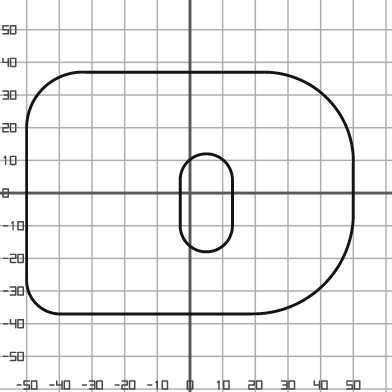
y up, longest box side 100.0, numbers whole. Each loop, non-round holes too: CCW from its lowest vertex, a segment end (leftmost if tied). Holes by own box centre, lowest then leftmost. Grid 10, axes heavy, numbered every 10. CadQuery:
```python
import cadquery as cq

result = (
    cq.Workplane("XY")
    .moveTo(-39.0, -37.0)
    .lineTo(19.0, -37.0)
    .threePointArc((41.0, -28.0), (50.0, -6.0))
    .lineTo(50.0, 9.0)
    .threePointArc((42.0, 29.0), (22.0, 37.0))
    .lineTo(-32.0, 37.0)
    .threePointArc((-45.0, 32.0), (-50.0, 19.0))
    .lineTo(-50.0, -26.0)
    .threePointArc((-47.0, -34.0), (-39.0, -37.0))
    .close()
    .moveTo(-3.0, -10.0)
    .threePointArc((5.0, -18.0), (13.0, -10.0))
    .lineTo(13.0, 4.0)
    .threePointArc((5.0, 12.0), (-3.0, 4.0))
    .close()
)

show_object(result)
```